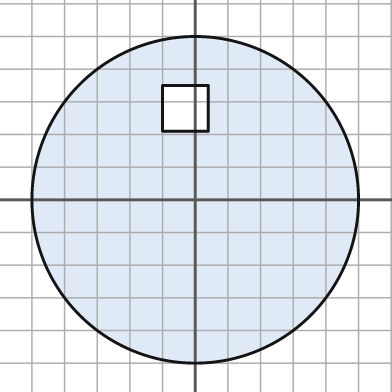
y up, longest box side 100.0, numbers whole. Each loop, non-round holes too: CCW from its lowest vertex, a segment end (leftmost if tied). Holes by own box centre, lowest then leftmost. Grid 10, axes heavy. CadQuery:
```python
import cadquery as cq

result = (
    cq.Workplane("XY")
    .moveTo(0.0, 0.0)
    .circle(50.0)
    .moveTo(-10.0, 21.0)
    .lineTo(4.0, 21.0)
    .lineTo(4.0, 35.0)
    .lineTo(-10.0, 35.0)
    .close()
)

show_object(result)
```